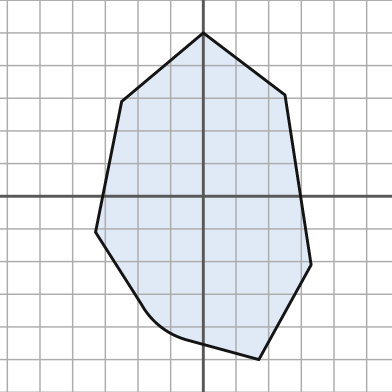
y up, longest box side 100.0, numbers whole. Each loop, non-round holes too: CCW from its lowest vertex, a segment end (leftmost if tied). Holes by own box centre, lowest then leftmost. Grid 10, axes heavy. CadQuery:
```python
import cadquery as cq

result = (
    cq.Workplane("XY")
    .moveTo(17.0, -50.0)
    .lineTo(33.0, -21.0)
    .lineTo(25.0, 31.0)
    .lineTo(0.0, 50.0)
    .lineTo(-25.0, 29.0)
    .lineTo(-33.0, -11.0)
    .lineTo(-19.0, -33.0)
    .threePointArc((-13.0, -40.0), (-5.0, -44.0))
    .close()
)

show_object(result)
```